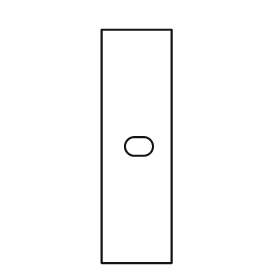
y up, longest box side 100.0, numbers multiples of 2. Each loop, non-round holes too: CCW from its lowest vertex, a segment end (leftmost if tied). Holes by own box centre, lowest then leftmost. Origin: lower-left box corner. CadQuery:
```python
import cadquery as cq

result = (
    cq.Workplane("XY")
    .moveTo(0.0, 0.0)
    .lineTo(30.0, 0.0)
    .lineTo(30.0, 100.0)
    .lineTo(0.0, 100.0)
    .close()
    .moveTo(14.0, 46.0)
    .lineTo(18.0, 46.0)
    .threePointArc((22.0, 50.0), (18.0, 54.0))
    .lineTo(14.0, 54.0)
    .threePointArc((10.0, 50.0), (14.0, 46.0))
    .close()
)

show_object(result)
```